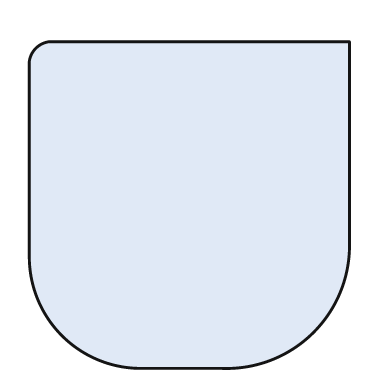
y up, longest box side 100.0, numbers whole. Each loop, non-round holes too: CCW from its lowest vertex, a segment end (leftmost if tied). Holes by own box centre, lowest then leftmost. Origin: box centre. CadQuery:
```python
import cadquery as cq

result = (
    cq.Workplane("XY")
    .moveTo(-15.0, -50.0)
    .lineTo(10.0, -50.0)
    .threePointArc((38.0, -39.0), (49.0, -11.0))
    .lineTo(49.0, 50.0)
    .lineTo(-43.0, 50.0)
    .threePointArc((-47.0, 48.0), (-49.0, 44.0))
    .lineTo(-49.0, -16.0)
    .threePointArc((-39.0, -40.0), (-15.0, -50.0))
    .close()
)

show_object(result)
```